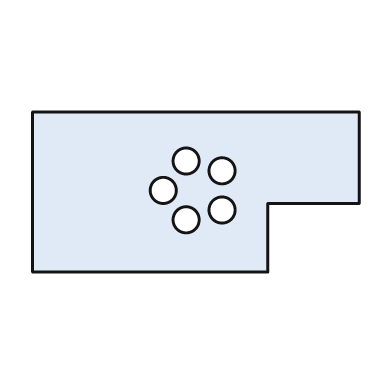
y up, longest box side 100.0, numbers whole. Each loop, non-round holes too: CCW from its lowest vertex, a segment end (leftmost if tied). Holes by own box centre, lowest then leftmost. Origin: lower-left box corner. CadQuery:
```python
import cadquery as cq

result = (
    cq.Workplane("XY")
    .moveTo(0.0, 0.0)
    .lineTo(72.0, 0.0)
    .lineTo(72.0, 21.0)
    .lineTo(100.0, 21.0)
    .lineTo(100.0, 49.0)
    .lineTo(0.0, 49.0)
    .close()
    .moveTo(47.0, 16.0)
    .circle(4.0)
    .moveTo(58.0, 19.0)
    .circle(4.0)
    .moveTo(40.0, 25.0)
    .circle(4.0)
    .moveTo(58.0, 31.0)
    .circle(4.0)
    .moveTo(47.0, 34.0)
    .circle(4.0)
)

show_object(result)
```